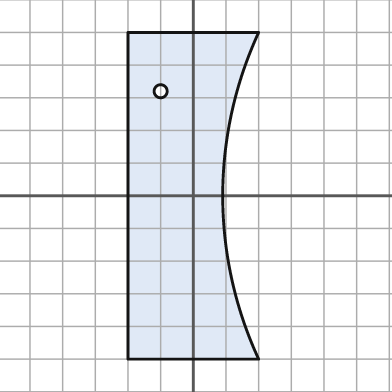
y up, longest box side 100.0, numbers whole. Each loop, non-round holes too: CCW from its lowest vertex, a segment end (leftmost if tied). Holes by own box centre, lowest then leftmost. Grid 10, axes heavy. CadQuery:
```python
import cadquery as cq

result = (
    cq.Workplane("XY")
    .moveTo(-20.0, -50.0)
    .lineTo(20.0, -50.0)
    .threePointArc((9.0, 0.0), (20.0, 50.0))
    .lineTo(-20.0, 50.0)
    .close()
    .moveTo(-10.0, 32.0)
    .circle(2.0)
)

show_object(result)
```